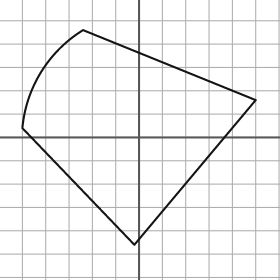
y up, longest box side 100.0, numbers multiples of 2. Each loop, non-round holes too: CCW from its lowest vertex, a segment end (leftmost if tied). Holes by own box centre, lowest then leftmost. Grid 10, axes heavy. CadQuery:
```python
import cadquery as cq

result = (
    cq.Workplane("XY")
    .moveTo(-2.0, -46.0)
    .lineTo(50.0, 16.0)
    .lineTo(-24.0, 46.0)
    .threePointArc((-42.0, 28.0), (-50.0, 4.0))
    .close()
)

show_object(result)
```